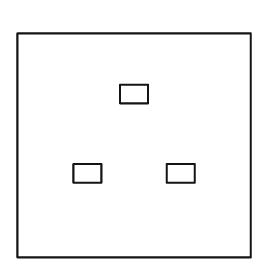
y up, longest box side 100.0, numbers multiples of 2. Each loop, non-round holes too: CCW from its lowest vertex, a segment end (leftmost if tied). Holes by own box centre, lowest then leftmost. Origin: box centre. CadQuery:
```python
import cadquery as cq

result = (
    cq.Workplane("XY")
    .moveTo(-50.0, -48.0)
    .lineTo(50.0, -48.0)
    .lineTo(50.0, 48.0)
    .lineTo(-50.0, 48.0)
    .close()
    .moveTo(-26.0, -16.0)
    .lineTo(-14.0, -16.0)
    .lineTo(-14.0, -8.0)
    .lineTo(-26.0, -8.0)
    .close()
    .moveTo(14.0, -16.0)
    .lineTo(26.0, -16.0)
    .lineTo(26.0, -8.0)
    .lineTo(14.0, -8.0)
    .close()
    .moveTo(-6.0, 18.0)
    .lineTo(6.0, 18.0)
    .lineTo(6.0, 26.0)
    .lineTo(-6.0, 26.0)
    .close()
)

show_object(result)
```